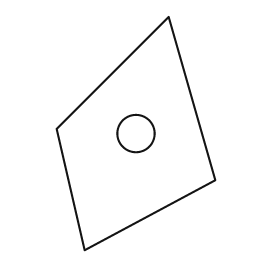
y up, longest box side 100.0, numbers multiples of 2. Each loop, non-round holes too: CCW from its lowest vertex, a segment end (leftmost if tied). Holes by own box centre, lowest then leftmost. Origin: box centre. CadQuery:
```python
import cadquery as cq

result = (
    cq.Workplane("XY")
    .moveTo(-22.0, -50.0)
    .lineTo(34.0, -20.0)
    .lineTo(14.0, 50.0)
    .lineTo(-34.0, 2.0)
    .close()
    .moveTo(0.0, 0.0)
    .circle(8.0)
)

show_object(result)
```